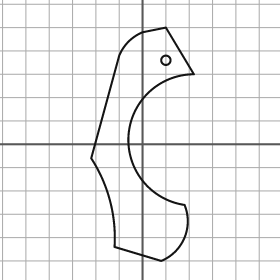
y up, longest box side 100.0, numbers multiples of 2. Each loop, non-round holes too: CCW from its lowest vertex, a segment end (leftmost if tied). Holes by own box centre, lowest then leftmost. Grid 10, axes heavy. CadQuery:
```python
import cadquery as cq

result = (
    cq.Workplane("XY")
    .moveTo(8.0, -50.0)
    .threePointArc((18.0, -40.0), (18.0, -26.0))
    .threePointArc((-6.0, 4.0), (22.0, 30.0))
    .lineTo(10.0, 50.0)
    .lineTo(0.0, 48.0)
    .threePointArc((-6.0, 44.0), (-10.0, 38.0))
    .lineTo(-22.0, -6.0)
    .threePointArc((-14.0, -24.0), (-12.0, -44.0))
    .close()
    .moveTo(10.0, 36.0)
    .circle(2.0)
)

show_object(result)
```